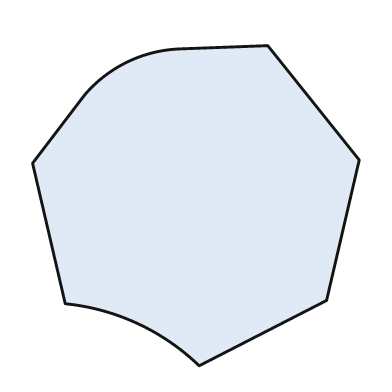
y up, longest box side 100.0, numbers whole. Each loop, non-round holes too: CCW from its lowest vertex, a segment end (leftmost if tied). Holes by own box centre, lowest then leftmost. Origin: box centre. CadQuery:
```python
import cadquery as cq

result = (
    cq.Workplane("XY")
    .moveTo(1.0, -49.0)
    .lineTo(40.0, -29.0)
    .lineTo(50.0, 14.0)
    .lineTo(22.0, 49.0)
    .lineTo(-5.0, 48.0)
    .threePointArc((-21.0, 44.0), (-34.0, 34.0))
    .lineTo(-50.0, 13.0)
    .lineTo(-40.0, -30.0)
    .threePointArc((-18.0, -36.0), (1.0, -49.0))
    .close()
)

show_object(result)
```